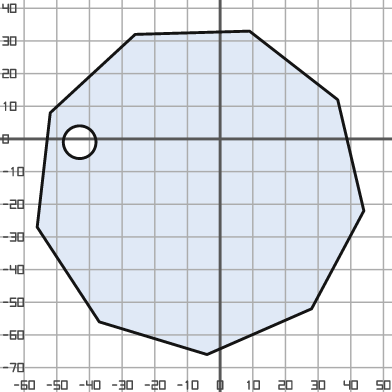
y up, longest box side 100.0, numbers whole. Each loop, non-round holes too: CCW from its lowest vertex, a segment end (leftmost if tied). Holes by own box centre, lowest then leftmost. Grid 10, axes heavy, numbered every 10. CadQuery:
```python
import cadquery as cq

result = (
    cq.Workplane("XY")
    .moveTo(-4.0, -66.0)
    .lineTo(28.0, -52.0)
    .lineTo(44.0, -22.0)
    .lineTo(36.0, 12.0)
    .lineTo(9.0, 33.0)
    .lineTo(-26.0, 32.0)
    .lineTo(-52.0, 8.0)
    .lineTo(-56.0, -27.0)
    .lineTo(-37.0, -56.0)
    .close()
    .moveTo(-43.0, -1.0)
    .circle(5.0)
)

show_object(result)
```